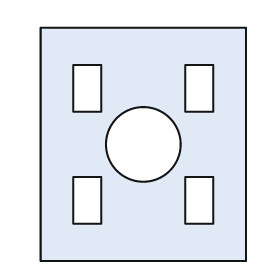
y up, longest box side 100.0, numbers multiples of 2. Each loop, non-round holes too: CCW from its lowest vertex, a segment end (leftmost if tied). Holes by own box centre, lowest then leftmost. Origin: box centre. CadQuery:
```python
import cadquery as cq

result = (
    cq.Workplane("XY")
    .moveTo(-44.0, -50.0)
    .lineTo(44.0, -50.0)
    .lineTo(44.0, 50.0)
    .lineTo(-44.0, 50.0)
    .close()
    .moveTo(-30.0, -34.0)
    .lineTo(-18.0, -34.0)
    .lineTo(-18.0, -14.0)
    .lineTo(-30.0, -14.0)
    .close()
    .moveTo(18.0, -34.0)
    .lineTo(30.0, -34.0)
    .lineTo(30.0, -14.0)
    .lineTo(18.0, -14.0)
    .close()
    .moveTo(0.0, 0.0)
    .circle(16.0)
    .moveTo(-30.0, 14.0)
    .lineTo(-18.0, 14.0)
    .lineTo(-18.0, 34.0)
    .lineTo(-30.0, 34.0)
    .close()
    .moveTo(18.0, 14.0)
    .lineTo(30.0, 14.0)
    .lineTo(30.0, 34.0)
    .lineTo(18.0, 34.0)
    .close()
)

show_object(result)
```